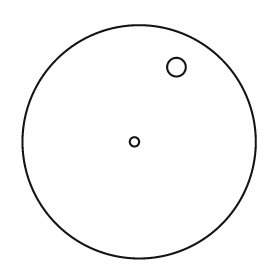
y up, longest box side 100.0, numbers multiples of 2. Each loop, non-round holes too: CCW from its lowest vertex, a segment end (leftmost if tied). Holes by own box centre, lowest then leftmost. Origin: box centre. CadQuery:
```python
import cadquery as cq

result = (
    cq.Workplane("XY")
    .moveTo(0.0, 0.0)
    .circle(50.0)
    .moveTo(-2.0, 0.0)
    .circle(2.0)
    .moveTo(16.0, 32.0)
    .circle(4.0)
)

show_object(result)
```